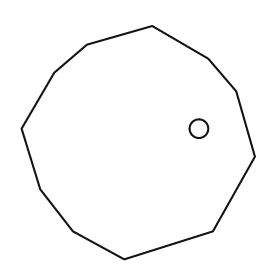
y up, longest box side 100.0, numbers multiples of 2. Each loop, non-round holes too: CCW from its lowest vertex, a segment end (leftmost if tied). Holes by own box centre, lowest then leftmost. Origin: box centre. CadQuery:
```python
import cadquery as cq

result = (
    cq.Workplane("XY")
    .moveTo(-6.0, -50.0)
    .lineTo(32.0, -38.0)
    .lineTo(50.0, -6.0)
    .lineTo(42.0, 22.0)
    .lineTo(30.0, 36.0)
    .lineTo(6.0, 50.0)
    .lineTo(-22.0, 42.0)
    .lineTo(-36.0, 30.0)
    .lineTo(-50.0, 6.0)
    .lineTo(-42.0, -20.0)
    .lineTo(-28.0, -38.0)
    .close()
    .moveTo(26.0, 6.0)
    .circle(4.0)
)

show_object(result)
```